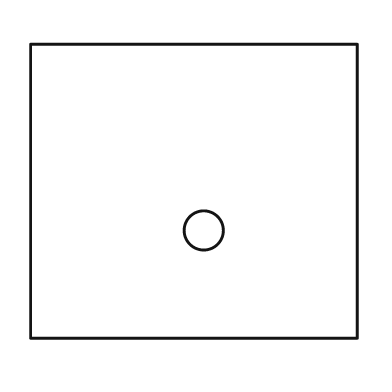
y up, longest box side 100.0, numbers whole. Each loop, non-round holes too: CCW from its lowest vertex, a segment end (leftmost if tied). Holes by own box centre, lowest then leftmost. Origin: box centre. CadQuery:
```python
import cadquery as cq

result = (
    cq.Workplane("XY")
    .moveTo(-50.0, -45.0)
    .lineTo(50.0, -45.0)
    .lineTo(50.0, 45.0)
    .lineTo(-50.0, 45.0)
    .close()
    .moveTo(3.0, -12.0)
    .circle(6.0)
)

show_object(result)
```